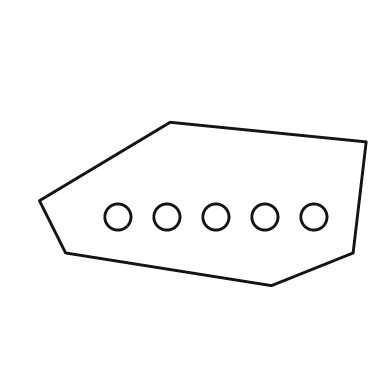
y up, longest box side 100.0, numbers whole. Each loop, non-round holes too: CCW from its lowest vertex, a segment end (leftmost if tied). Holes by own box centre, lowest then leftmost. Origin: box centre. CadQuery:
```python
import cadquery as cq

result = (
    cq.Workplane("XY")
    .moveTo(21.0, -25.0)
    .lineTo(46.0, -15.0)
    .lineTo(50.0, 19.0)
    .lineTo(-10.0, 25.0)
    .lineTo(-50.0, 1.0)
    .lineTo(-42.0, -15.0)
    .close()
    .moveTo(-26.0, -4.0)
    .circle(4.0)
    .moveTo(-11.0, -4.0)
    .circle(4.0)
    .moveTo(4.0, -4.0)
    .circle(4.0)
    .moveTo(19.0, -4.0)
    .circle(4.0)
    .moveTo(34.0, -4.0)
    .circle(4.0)
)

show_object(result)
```